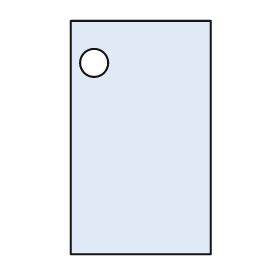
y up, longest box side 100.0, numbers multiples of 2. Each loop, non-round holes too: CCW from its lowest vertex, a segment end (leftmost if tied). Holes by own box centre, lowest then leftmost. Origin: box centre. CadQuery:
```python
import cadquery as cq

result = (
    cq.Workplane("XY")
    .moveTo(-30.0, -50.0)
    .lineTo(30.0, -50.0)
    .lineTo(30.0, 50.0)
    .lineTo(-30.0, 50.0)
    .close()
    .moveTo(-20.0, 32.0)
    .circle(6.0)
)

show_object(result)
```